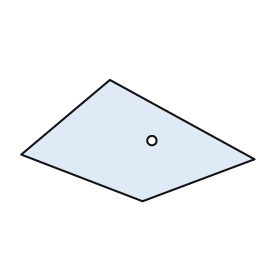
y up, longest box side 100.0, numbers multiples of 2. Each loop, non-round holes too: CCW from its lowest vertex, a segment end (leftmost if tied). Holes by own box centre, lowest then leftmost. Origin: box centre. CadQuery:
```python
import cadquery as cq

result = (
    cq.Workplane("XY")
    .moveTo(2.0, -26.0)
    .lineTo(50.0, -8.0)
    .lineTo(-12.0, 26.0)
    .lineTo(-50.0, -6.0)
    .close()
    .moveTo(6.0, 0.0)
    .circle(2.0)
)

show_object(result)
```